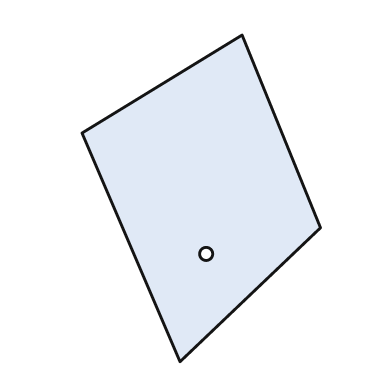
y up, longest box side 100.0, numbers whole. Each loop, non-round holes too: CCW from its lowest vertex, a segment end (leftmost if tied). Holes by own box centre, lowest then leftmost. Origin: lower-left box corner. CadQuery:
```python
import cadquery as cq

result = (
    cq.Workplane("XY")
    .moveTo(30.0, 0.0)
    .lineTo(73.0, 41.0)
    .lineTo(49.0, 100.0)
    .lineTo(0.0, 70.0)
    .close()
    .moveTo(38.0, 33.0)
    .circle(2.0)
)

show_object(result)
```